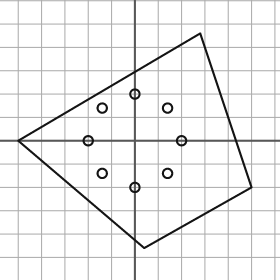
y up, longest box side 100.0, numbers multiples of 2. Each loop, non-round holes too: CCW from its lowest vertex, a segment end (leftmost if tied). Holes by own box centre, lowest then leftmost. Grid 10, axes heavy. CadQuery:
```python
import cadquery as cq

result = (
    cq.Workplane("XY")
    .moveTo(4.0, -46.0)
    .lineTo(50.0, -20.0)
    .lineTo(28.0, 46.0)
    .lineTo(-50.0, 0.0)
    .close()
    .moveTo(0.0, -20.0)
    .circle(2.0)
    .moveTo(-14.0, -14.0)
    .circle(2.0)
    .moveTo(14.0, -14.0)
    .circle(2.0)
    .moveTo(-20.0, 0.0)
    .circle(2.0)
    .moveTo(20.0, 0.0)
    .circle(2.0)
    .moveTo(-14.0, 14.0)
    .circle(2.0)
    .moveTo(14.0, 14.0)
    .circle(2.0)
    .moveTo(0.0, 20.0)
    .circle(2.0)
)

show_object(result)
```